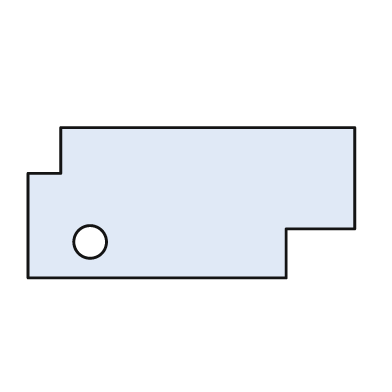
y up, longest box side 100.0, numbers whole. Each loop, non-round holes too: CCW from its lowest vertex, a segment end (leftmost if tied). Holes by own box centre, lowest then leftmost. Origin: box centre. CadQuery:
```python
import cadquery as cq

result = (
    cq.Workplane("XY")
    .moveTo(-50.0, -23.0)
    .lineTo(29.0, -23.0)
    .lineTo(29.0, -8.0)
    .lineTo(50.0, -8.0)
    .lineTo(50.0, 23.0)
    .lineTo(-40.0, 23.0)
    .lineTo(-40.0, 9.0)
    .lineTo(-50.0, 9.0)
    .close()
    .moveTo(-31.0, -12.0)
    .circle(5.0)
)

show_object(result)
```